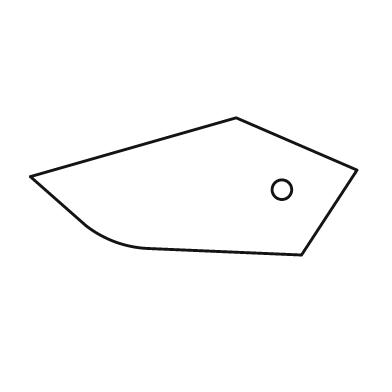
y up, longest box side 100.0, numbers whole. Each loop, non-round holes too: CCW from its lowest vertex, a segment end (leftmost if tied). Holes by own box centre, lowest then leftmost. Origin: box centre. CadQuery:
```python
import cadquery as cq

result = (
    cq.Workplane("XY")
    .moveTo(33.0, -21.0)
    .lineTo(50.0, 5.0)
    .lineTo(13.0, 21.0)
    .lineTo(-50.0, 3.0)
    .lineTo(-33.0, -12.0)
    .threePointArc((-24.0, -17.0), (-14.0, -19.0))
    .close()
    .moveTo(27.0, -1.0)
    .circle(3.0)
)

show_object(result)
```